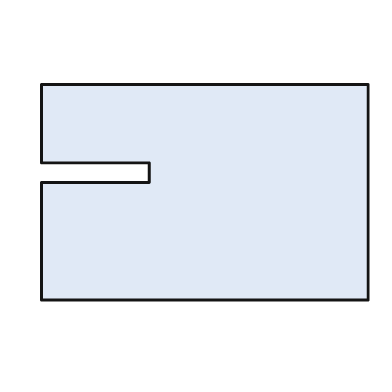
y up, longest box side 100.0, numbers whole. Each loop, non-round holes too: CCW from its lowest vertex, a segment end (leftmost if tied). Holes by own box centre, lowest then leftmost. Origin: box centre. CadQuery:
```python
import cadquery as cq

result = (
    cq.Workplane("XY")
    .moveTo(-50.0, -33.0)
    .lineTo(50.0, -33.0)
    .lineTo(50.0, 33.0)
    .lineTo(-50.0, 33.0)
    .lineTo(-50.0, 9.0)
    .lineTo(-17.0, 9.0)
    .lineTo(-17.0, 3.0)
    .lineTo(-50.0, 3.0)
    .close()
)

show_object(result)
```